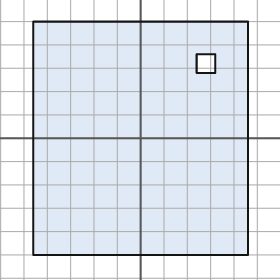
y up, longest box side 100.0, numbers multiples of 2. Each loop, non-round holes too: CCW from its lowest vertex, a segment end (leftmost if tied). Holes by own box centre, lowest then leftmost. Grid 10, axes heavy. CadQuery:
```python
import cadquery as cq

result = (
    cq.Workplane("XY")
    .moveTo(-46.0, -50.0)
    .lineTo(46.0, -50.0)
    .lineTo(46.0, 50.0)
    .lineTo(-46.0, 50.0)
    .close()
    .moveTo(24.0, 28.0)
    .lineTo(32.0, 28.0)
    .lineTo(32.0, 36.0)
    .lineTo(24.0, 36.0)
    .close()
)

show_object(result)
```